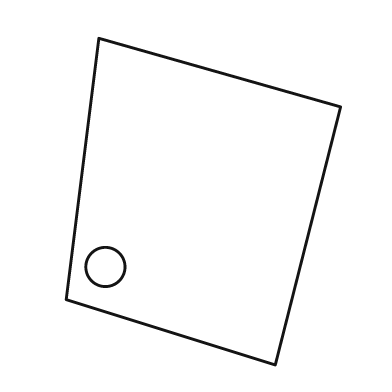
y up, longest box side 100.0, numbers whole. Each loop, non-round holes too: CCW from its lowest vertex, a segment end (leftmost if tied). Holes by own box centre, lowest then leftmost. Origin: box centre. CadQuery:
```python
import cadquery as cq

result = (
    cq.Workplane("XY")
    .moveTo(22.0, -50.0)
    .lineTo(42.0, 29.0)
    .lineTo(-32.0, 50.0)
    .lineTo(-42.0, -30.0)
    .close()
    .moveTo(-30.0, -20.0)
    .circle(6.0)
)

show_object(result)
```